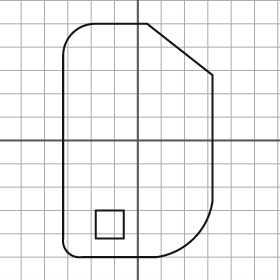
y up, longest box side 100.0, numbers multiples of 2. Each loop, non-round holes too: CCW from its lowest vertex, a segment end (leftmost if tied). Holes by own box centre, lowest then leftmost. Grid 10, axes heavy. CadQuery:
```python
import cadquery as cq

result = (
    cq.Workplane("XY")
    .moveTo(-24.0, -50.0)
    .lineTo(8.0, -50.0)
    .threePointArc((24.0, -42.0), (32.0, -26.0))
    .lineTo(32.0, 28.0)
    .lineTo(4.0, 50.0)
    .lineTo(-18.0, 50.0)
    .threePointArc((-28.0, 46.0), (-32.0, 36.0))
    .lineTo(-32.0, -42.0)
    .threePointArc((-30.0, -48.0), (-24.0, -50.0))
    .close()
    .moveTo(-18.0, -42.0)
    .lineTo(-6.0, -42.0)
    .lineTo(-6.0, -30.0)
    .lineTo(-18.0, -30.0)
    .close()
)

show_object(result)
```